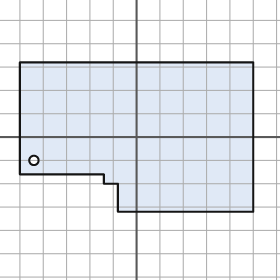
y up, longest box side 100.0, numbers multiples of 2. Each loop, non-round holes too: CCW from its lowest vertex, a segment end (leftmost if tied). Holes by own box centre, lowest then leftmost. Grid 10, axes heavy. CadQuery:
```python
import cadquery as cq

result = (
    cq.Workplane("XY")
    .moveTo(-8.0, -32.0)
    .lineTo(50.0, -32.0)
    .lineTo(50.0, 32.0)
    .lineTo(-50.0, 32.0)
    .lineTo(-50.0, -16.0)
    .lineTo(-14.0, -16.0)
    .lineTo(-14.0, -20.0)
    .lineTo(-8.0, -20.0)
    .close()
    .moveTo(-44.0, -10.0)
    .circle(2.0)
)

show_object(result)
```